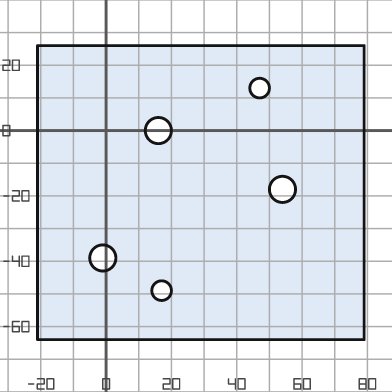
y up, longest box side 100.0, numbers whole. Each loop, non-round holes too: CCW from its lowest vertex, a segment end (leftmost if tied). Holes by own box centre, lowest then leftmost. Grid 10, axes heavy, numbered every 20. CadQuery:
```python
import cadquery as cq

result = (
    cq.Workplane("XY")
    .moveTo(-21.0, -64.0)
    .lineTo(79.0, -64.0)
    .lineTo(79.0, 26.0)
    .lineTo(-21.0, 26.0)
    .close()
    .moveTo(17.0, -49.0)
    .circle(3.0)
    .moveTo(-1.0, -39.0)
    .circle(4.0)
    .moveTo(54.0, -18.0)
    .circle(4.0)
    .moveTo(16.0, 0.0)
    .circle(4.0)
    .moveTo(47.0, 13.0)
    .circle(3.0)
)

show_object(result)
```